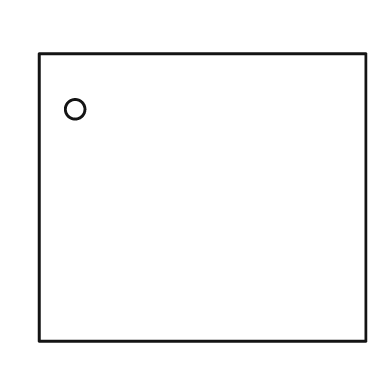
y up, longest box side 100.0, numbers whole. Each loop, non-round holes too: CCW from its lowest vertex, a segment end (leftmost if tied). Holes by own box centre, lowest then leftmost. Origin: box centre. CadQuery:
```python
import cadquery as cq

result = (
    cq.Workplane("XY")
    .moveTo(-50.0, -44.0)
    .lineTo(50.0, -44.0)
    .lineTo(50.0, 44.0)
    .lineTo(-50.0, 44.0)
    .close()
    .moveTo(-39.0, 27.0)
    .circle(3.0)
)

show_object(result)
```